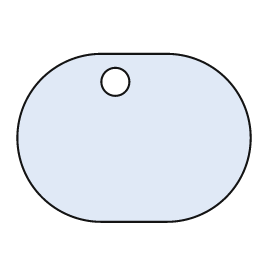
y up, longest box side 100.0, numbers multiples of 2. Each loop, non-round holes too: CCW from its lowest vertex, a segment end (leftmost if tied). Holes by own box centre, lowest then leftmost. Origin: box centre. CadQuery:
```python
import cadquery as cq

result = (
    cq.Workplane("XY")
    .moveTo(-14.0, -36.0)
    .lineTo(14.0, -36.0)
    .threePointArc((50.0, 0.0), (14.0, 36.0))
    .lineTo(-14.0, 36.0)
    .threePointArc((-50.0, 0.0), (-14.0, -36.0))
    .close()
    .moveTo(-8.0, 24.0)
    .circle(6.0)
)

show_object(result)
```